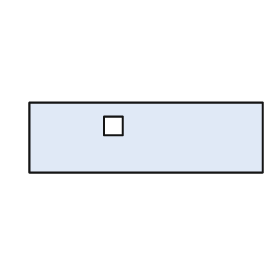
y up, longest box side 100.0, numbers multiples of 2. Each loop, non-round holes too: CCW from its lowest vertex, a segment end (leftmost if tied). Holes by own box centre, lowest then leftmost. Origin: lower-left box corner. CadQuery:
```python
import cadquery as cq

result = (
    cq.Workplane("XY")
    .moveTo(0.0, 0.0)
    .lineTo(100.0, 0.0)
    .lineTo(100.0, 30.0)
    .lineTo(0.0, 30.0)
    .close()
    .moveTo(32.0, 16.0)
    .lineTo(40.0, 16.0)
    .lineTo(40.0, 24.0)
    .lineTo(32.0, 24.0)
    .close()
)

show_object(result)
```